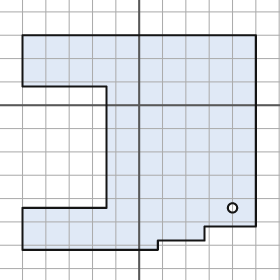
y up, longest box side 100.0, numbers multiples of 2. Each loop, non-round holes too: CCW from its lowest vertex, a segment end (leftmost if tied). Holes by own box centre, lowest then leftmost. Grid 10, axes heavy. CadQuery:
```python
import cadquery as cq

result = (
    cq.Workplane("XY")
    .moveTo(-50.0, -62.0)
    .lineTo(8.0, -62.0)
    .lineTo(8.0, -58.0)
    .lineTo(28.0, -58.0)
    .lineTo(28.0, -52.0)
    .lineTo(50.0, -52.0)
    .lineTo(50.0, 30.0)
    .lineTo(-50.0, 30.0)
    .lineTo(-50.0, 8.0)
    .lineTo(-14.0, 8.0)
    .lineTo(-14.0, -44.0)
    .lineTo(-50.0, -44.0)
    .close()
    .moveTo(40.0, -44.0)
    .circle(2.0)
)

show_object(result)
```